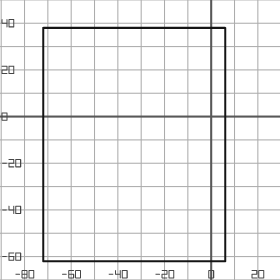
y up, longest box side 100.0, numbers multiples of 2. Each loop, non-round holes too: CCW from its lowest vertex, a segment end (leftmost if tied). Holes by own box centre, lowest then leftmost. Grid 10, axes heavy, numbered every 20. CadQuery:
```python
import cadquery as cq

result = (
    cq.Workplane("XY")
    .moveTo(-72.0, -62.0)
    .lineTo(6.0, -62.0)
    .lineTo(6.0, 38.0)
    .lineTo(-72.0, 38.0)
    .close()
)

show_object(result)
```